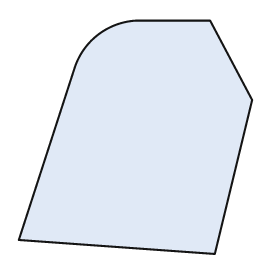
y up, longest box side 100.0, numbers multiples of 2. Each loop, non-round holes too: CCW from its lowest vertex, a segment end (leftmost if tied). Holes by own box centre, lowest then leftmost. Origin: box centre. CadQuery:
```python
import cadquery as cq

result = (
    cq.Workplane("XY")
    .moveTo(34.0, -50.0)
    .lineTo(50.0, 16.0)
    .lineTo(32.0, 50.0)
    .lineTo(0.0, 50.0)
    .threePointArc((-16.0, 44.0), (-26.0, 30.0))
    .lineTo(-50.0, -44.0)
    .close()
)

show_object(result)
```